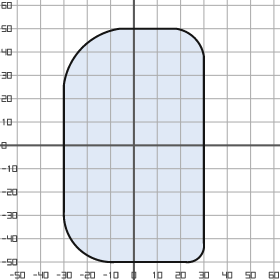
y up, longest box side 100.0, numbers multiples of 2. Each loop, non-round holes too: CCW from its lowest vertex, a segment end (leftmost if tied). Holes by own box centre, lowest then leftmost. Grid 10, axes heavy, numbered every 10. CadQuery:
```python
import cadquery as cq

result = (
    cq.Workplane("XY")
    .moveTo(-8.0, -50.0)
    .lineTo(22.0, -50.0)
    .threePointArc((28.0, -48.0), (30.0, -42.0))
    .lineTo(30.0, 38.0)
    .threePointArc((26.0, 46.0), (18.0, 50.0))
    .lineTo(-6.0, 50.0)
    .threePointArc((-22.0, 42.0), (-30.0, 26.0))
    .lineTo(-30.0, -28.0)
    .threePointArc((-24.0, -44.0), (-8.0, -50.0))
    .close()
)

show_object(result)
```